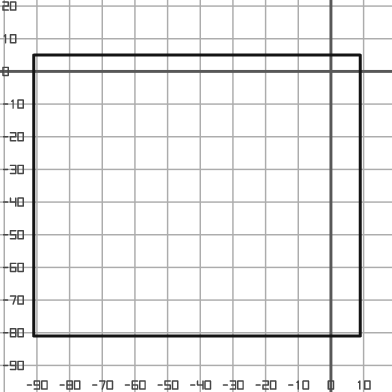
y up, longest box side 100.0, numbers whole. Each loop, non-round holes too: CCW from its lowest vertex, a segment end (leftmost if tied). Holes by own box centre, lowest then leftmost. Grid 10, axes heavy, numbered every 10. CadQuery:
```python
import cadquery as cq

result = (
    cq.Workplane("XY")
    .moveTo(-91.0, -81.0)
    .lineTo(9.0, -81.0)
    .lineTo(9.0, 5.0)
    .lineTo(-91.0, 5.0)
    .close()
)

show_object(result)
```